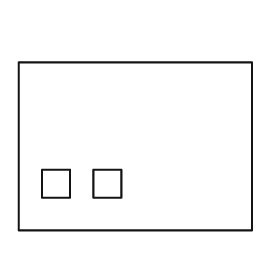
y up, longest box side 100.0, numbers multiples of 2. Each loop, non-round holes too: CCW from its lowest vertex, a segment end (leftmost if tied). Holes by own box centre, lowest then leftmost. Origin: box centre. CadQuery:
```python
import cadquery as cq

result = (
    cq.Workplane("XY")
    .moveTo(-50.0, -36.0)
    .lineTo(50.0, -36.0)
    .lineTo(50.0, 36.0)
    .lineTo(-50.0, 36.0)
    .close()
    .moveTo(-40.0, -22.0)
    .lineTo(-28.0, -22.0)
    .lineTo(-28.0, -10.0)
    .lineTo(-40.0, -10.0)
    .close()
    .moveTo(-18.0, -22.0)
    .lineTo(-6.0, -22.0)
    .lineTo(-6.0, -10.0)
    .lineTo(-18.0, -10.0)
    .close()
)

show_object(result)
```